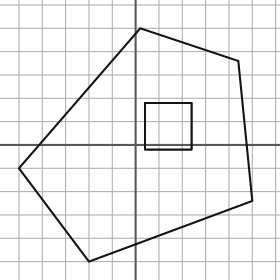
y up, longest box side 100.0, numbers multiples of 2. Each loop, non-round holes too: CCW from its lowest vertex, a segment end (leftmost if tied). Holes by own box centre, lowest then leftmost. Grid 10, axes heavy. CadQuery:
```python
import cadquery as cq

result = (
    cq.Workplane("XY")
    .moveTo(-20.0, -50.0)
    .lineTo(50.0, -24.0)
    .lineTo(44.0, 36.0)
    .lineTo(2.0, 50.0)
    .lineTo(-50.0, -10.0)
    .close()
    .moveTo(4.0, -2.0)
    .lineTo(24.0, -2.0)
    .lineTo(24.0, 18.0)
    .lineTo(4.0, 18.0)
    .close()
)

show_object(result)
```